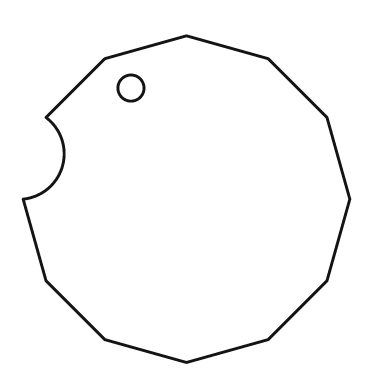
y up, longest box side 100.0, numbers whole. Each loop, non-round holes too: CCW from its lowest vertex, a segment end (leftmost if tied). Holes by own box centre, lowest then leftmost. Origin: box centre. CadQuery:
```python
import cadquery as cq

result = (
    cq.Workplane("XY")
    .moveTo(0.0, -50.0)
    .lineTo(25.0, -43.0)
    .lineTo(43.0, -25.0)
    .lineTo(50.0, 0.0)
    .lineTo(43.0, 25.0)
    .lineTo(25.0, 43.0)
    .lineTo(0.0, 50.0)
    .lineTo(-25.0, 43.0)
    .lineTo(-43.0, 25.0)
    .threePointArc((-38.0, 10.0), (-50.0, 0.0))
    .lineTo(-43.0, -25.0)
    .lineTo(-25.0, -43.0)
    .close()
    .moveTo(-17.0, 34.0)
    .circle(4.0)
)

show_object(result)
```